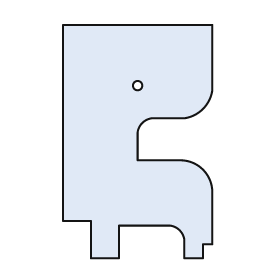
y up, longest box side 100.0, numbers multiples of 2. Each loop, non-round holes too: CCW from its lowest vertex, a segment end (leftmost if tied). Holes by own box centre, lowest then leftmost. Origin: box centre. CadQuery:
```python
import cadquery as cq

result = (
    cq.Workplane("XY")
    .moveTo(-20.0, -50.0)
    .lineTo(-8.0, -50.0)
    .lineTo(-8.0, -36.0)
    .lineTo(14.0, -36.0)
    .threePointArc((18.0, -38.0), (20.0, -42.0))
    .lineTo(20.0, -50.0)
    .lineTo(28.0, -50.0)
    .lineTo(28.0, -44.0)
    .lineTo(32.0, -44.0)
    .lineTo(32.0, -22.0)
    .threePointArc((28.0, -12.0), (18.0, -8.0))
    .lineTo(0.0, -8.0)
    .lineTo(0.0, 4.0)
    .threePointArc((2.0, 8.0), (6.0, 10.0))
    .lineTo(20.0, 10.0)
    .threePointArc((28.0, 14.0), (32.0, 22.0))
    .lineTo(32.0, 50.0)
    .lineTo(-32.0, 50.0)
    .lineTo(-32.0, -34.0)
    .lineTo(-20.0, -34.0)
    .close()
    .moveTo(0.0, 24.0)
    .circle(2.0)
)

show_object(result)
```